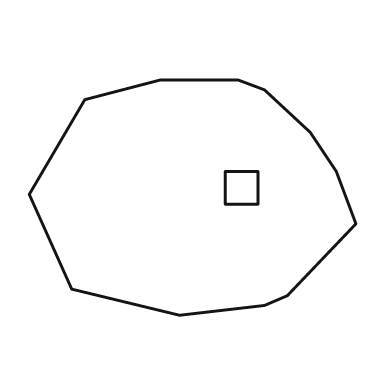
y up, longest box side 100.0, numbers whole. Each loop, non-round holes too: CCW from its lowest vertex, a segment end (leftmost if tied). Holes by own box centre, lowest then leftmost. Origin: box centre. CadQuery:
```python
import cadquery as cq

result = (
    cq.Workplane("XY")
    .moveTo(-4.0, -36.0)
    .lineTo(22.0, -33.0)
    .lineTo(29.0, -30.0)
    .lineTo(50.0, -8.0)
    .lineTo(44.0, 8.0)
    .lineTo(36.0, 20.0)
    .lineTo(22.0, 33.0)
    .lineTo(14.0, 36.0)
    .lineTo(-10.0, 36.0)
    .lineTo(-33.0, 30.0)
    .lineTo(-50.0, 1.0)
    .lineTo(-37.0, -28.0)
    .close()
    .moveTo(10.0, -2.0)
    .lineTo(20.0, -2.0)
    .lineTo(20.0, 8.0)
    .lineTo(10.0, 8.0)
    .close()
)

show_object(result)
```